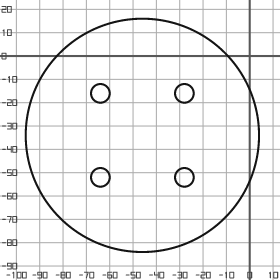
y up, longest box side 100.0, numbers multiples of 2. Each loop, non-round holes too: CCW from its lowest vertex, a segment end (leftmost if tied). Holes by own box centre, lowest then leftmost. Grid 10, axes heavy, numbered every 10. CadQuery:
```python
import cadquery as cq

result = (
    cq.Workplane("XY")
    .moveTo(-46.0, -34.0)
    .circle(50.0)
    .moveTo(-64.0, -52.0)
    .circle(4.0)
    .moveTo(-28.0, -52.0)
    .circle(4.0)
    .moveTo(-64.0, -16.0)
    .circle(4.0)
    .moveTo(-28.0, -16.0)
    .circle(4.0)
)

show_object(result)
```